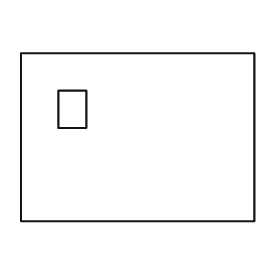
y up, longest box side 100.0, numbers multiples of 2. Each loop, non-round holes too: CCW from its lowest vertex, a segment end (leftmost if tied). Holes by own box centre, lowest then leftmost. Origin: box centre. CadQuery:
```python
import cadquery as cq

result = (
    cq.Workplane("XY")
    .moveTo(-50.0, -36.0)
    .lineTo(50.0, -36.0)
    .lineTo(50.0, 36.0)
    .lineTo(-50.0, 36.0)
    .close()
    .moveTo(-34.0, 4.0)
    .lineTo(-22.0, 4.0)
    .lineTo(-22.0, 20.0)
    .lineTo(-34.0, 20.0)
    .close()
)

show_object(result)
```